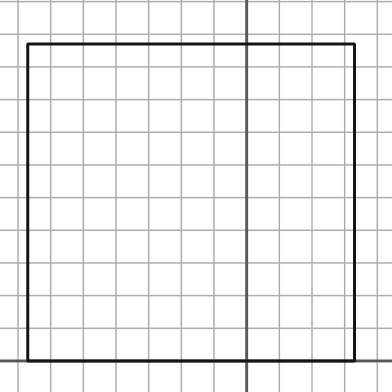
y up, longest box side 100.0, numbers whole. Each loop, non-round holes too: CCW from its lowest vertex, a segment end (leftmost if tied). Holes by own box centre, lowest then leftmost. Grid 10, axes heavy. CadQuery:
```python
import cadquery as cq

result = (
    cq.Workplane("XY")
    .moveTo(-67.0, 0.0)
    .lineTo(33.0, 0.0)
    .lineTo(33.0, 97.0)
    .lineTo(-67.0, 97.0)
    .close()
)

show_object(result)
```